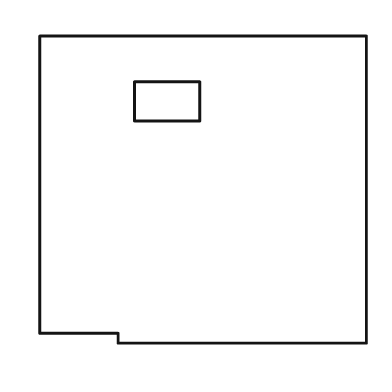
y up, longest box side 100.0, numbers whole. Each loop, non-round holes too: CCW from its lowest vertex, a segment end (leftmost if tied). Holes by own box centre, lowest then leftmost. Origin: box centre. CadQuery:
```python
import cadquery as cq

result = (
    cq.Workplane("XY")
    .moveTo(-26.0, -47.0)
    .lineTo(50.0, -47.0)
    .lineTo(50.0, 47.0)
    .lineTo(-50.0, 47.0)
    .lineTo(-50.0, -44.0)
    .lineTo(-26.0, -44.0)
    .close()
    .moveTo(-21.0, 21.0)
    .lineTo(-1.0, 21.0)
    .lineTo(-1.0, 33.0)
    .lineTo(-21.0, 33.0)
    .close()
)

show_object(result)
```